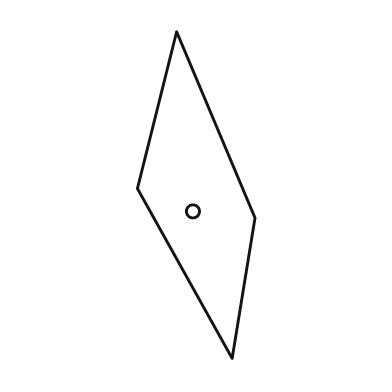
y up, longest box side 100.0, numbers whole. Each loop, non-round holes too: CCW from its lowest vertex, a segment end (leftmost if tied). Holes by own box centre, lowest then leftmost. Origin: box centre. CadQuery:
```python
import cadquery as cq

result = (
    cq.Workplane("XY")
    .moveTo(11.0, -50.0)
    .lineTo(18.0, -7.0)
    .lineTo(-6.0, 50.0)
    .lineTo(-18.0, 2.0)
    .close()
    .moveTo(-1.0, -5.0)
    .circle(2.0)
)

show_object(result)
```